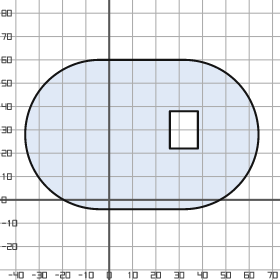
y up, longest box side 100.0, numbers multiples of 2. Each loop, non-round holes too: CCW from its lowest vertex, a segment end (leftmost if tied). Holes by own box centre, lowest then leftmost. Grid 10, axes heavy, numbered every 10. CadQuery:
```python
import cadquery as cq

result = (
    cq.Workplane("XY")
    .moveTo(-4.0, -4.0)
    .lineTo(32.0, -4.0)
    .threePointArc((64.0, 28.0), (32.0, 60.0))
    .lineTo(-4.0, 60.0)
    .threePointArc((-36.0, 28.0), (-4.0, -4.0))
    .close()
    .moveTo(26.0, 22.0)
    .lineTo(38.0, 22.0)
    .lineTo(38.0, 38.0)
    .lineTo(26.0, 38.0)
    .close()
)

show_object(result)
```